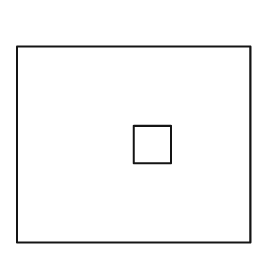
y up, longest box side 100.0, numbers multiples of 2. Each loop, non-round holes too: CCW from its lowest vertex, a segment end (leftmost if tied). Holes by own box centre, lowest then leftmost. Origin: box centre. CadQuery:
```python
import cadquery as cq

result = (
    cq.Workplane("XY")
    .moveTo(-50.0, -42.0)
    .lineTo(50.0, -42.0)
    .lineTo(50.0, 42.0)
    .lineTo(-50.0, 42.0)
    .close()
    .moveTo(0.0, -8.0)
    .lineTo(16.0, -8.0)
    .lineTo(16.0, 8.0)
    .lineTo(0.0, 8.0)
    .close()
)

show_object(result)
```